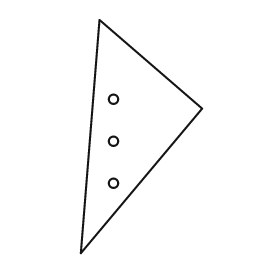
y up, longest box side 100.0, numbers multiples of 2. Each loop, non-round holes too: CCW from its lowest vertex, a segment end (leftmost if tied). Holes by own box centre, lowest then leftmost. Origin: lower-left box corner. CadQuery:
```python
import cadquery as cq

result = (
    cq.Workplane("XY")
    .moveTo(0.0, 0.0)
    .lineTo(52.0, 62.0)
    .lineTo(8.0, 100.0)
    .close()
    .moveTo(14.0, 30.0)
    .circle(2.0)
    .moveTo(14.0, 48.0)
    .circle(2.0)
    .moveTo(14.0, 66.0)
    .circle(2.0)
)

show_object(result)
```